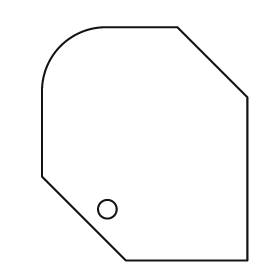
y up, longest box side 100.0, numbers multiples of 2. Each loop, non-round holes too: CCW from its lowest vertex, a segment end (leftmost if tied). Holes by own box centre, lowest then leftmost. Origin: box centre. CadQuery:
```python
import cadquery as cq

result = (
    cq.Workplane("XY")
    .moveTo(-8.0, -50.0)
    .lineTo(44.0, -50.0)
    .lineTo(44.0, 20.0)
    .lineTo(14.0, 50.0)
    .lineTo(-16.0, 50.0)
    .threePointArc((-36.0, 42.0), (-44.0, 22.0))
    .lineTo(-44.0, -14.0)
    .close()
    .moveTo(-16.0, -28.0)
    .circle(4.0)
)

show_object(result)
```